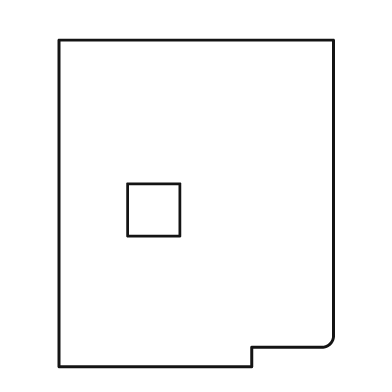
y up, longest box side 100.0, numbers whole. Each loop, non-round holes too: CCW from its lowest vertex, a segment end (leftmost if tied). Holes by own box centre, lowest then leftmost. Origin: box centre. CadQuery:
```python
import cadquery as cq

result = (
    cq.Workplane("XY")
    .moveTo(-42.0, -50.0)
    .lineTo(17.0, -50.0)
    .lineTo(17.0, -44.0)
    .lineTo(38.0, -44.0)
    .threePointArc((41.0, -43.0), (42.0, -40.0))
    .lineTo(42.0, 50.0)
    .lineTo(-42.0, 50.0)
    .close()
    .moveTo(-21.0, -10.0)
    .lineTo(-5.0, -10.0)
    .lineTo(-5.0, 6.0)
    .lineTo(-21.0, 6.0)
    .close()
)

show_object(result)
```